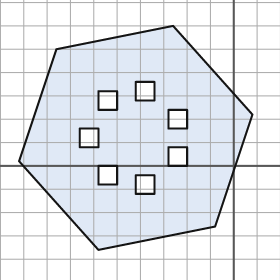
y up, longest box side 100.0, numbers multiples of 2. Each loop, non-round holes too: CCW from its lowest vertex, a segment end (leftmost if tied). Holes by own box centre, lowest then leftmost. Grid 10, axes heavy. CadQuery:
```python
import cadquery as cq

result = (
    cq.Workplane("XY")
    .moveTo(-58.0, -36.0)
    .lineTo(-8.0, -26.0)
    .lineTo(8.0, 22.0)
    .lineTo(-26.0, 60.0)
    .lineTo(-76.0, 50.0)
    .lineTo(-92.0, 2.0)
    .close()
    .moveTo(-42.0, -12.0)
    .lineTo(-34.0, -12.0)
    .lineTo(-34.0, -4.0)
    .lineTo(-42.0, -4.0)
    .close()
    .moveTo(-58.0, -8.0)
    .lineTo(-50.0, -8.0)
    .lineTo(-50.0, 0.0)
    .lineTo(-58.0, 0.0)
    .close()
    .moveTo(-28.0, 0.0)
    .lineTo(-20.0, 0.0)
    .lineTo(-20.0, 8.0)
    .lineTo(-28.0, 8.0)
    .close()
    .moveTo(-66.0, 8.0)
    .lineTo(-58.0, 8.0)
    .lineTo(-58.0, 16.0)
    .lineTo(-66.0, 16.0)
    .close()
    .moveTo(-28.0, 16.0)
    .lineTo(-20.0, 16.0)
    .lineTo(-20.0, 24.0)
    .lineTo(-28.0, 24.0)
    .close()
    .moveTo(-58.0, 24.0)
    .lineTo(-50.0, 24.0)
    .lineTo(-50.0, 32.0)
    .lineTo(-58.0, 32.0)
    .close()
    .moveTo(-42.0, 28.0)
    .lineTo(-34.0, 28.0)
    .lineTo(-34.0, 36.0)
    .lineTo(-42.0, 36.0)
    .close()
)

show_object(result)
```